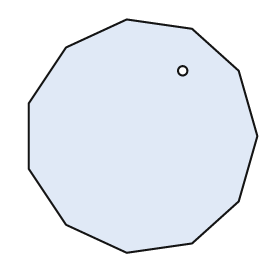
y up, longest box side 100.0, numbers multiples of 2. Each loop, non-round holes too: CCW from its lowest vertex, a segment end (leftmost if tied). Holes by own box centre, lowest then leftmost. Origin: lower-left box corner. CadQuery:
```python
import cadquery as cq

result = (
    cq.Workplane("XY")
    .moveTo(42.0, 0.0)
    .lineTo(70.0, 4.0)
    .lineTo(90.0, 22.0)
    .lineTo(98.0, 50.0)
    .lineTo(90.0, 78.0)
    .lineTo(70.0, 96.0)
    .lineTo(42.0, 100.0)
    .lineTo(16.0, 88.0)
    .lineTo(0.0, 64.0)
    .lineTo(0.0, 36.0)
    .lineTo(16.0, 12.0)
    .close()
    .moveTo(66.0, 78.0)
    .circle(2.0)
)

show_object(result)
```